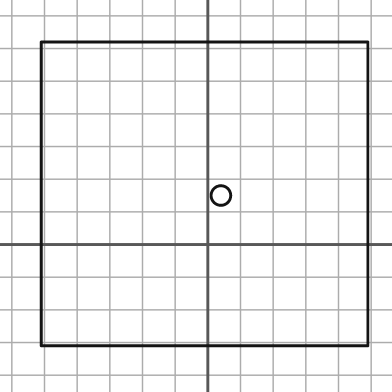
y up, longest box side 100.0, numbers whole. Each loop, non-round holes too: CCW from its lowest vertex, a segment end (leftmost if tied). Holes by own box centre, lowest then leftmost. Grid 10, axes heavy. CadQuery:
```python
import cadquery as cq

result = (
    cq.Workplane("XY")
    .moveTo(-51.0, -31.0)
    .lineTo(49.0, -31.0)
    .lineTo(49.0, 62.0)
    .lineTo(-51.0, 62.0)
    .close()
    .moveTo(4.0, 15.0)
    .circle(3.0)
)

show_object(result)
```